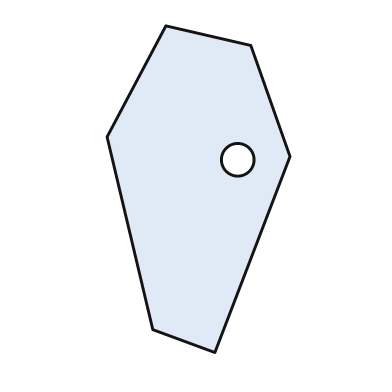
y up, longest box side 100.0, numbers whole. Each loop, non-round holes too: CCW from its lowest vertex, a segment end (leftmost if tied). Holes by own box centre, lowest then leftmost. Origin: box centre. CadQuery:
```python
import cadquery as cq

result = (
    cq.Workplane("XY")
    .moveTo(5.0, -50.0)
    .lineTo(28.0, 10.0)
    .lineTo(16.0, 44.0)
    .lineTo(-10.0, 50.0)
    .lineTo(-28.0, 16.0)
    .lineTo(-14.0, -43.0)
    .close()
    .moveTo(12.0, 9.0)
    .circle(5.0)
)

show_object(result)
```